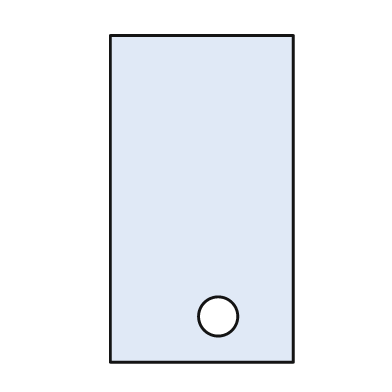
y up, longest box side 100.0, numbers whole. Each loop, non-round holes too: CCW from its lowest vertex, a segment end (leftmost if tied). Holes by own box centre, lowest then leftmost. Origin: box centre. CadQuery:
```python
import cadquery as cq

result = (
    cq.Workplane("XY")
    .moveTo(-28.0, -50.0)
    .lineTo(28.0, -50.0)
    .lineTo(28.0, 50.0)
    .lineTo(-28.0, 50.0)
    .close()
    .moveTo(5.0, -36.0)
    .circle(6.0)
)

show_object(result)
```